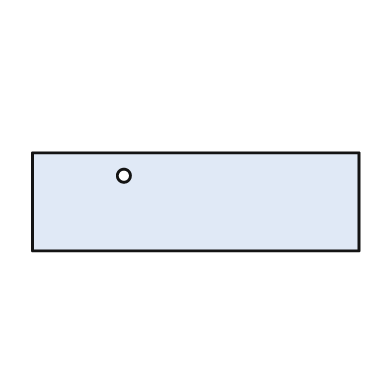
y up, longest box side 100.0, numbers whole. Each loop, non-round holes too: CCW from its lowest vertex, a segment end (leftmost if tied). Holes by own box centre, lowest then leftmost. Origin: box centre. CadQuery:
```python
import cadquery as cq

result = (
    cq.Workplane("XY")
    .moveTo(-50.0, -15.0)
    .lineTo(50.0, -15.0)
    .lineTo(50.0, 15.0)
    .lineTo(-50.0, 15.0)
    .close()
    .moveTo(-22.0, 8.0)
    .circle(2.0)
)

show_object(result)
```